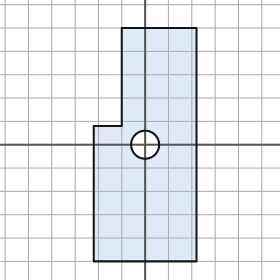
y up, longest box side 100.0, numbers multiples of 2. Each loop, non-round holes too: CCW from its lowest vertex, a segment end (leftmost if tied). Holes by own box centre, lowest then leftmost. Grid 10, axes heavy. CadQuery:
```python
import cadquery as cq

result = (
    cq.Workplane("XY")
    .moveTo(-22.0, -50.0)
    .lineTo(22.0, -50.0)
    .lineTo(22.0, 50.0)
    .lineTo(-10.0, 50.0)
    .lineTo(-10.0, 8.0)
    .lineTo(-22.0, 8.0)
    .close()
    .moveTo(0.0, 0.0)
    .circle(6.0)
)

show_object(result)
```